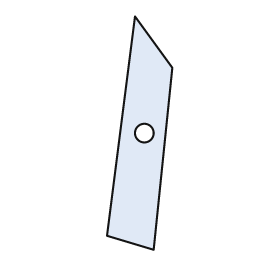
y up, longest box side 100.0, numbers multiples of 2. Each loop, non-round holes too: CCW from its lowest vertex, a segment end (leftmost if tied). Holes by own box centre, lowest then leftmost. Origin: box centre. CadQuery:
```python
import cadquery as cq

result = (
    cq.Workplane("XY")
    .moveTo(6.0, -50.0)
    .lineTo(14.0, 28.0)
    .lineTo(-2.0, 50.0)
    .lineTo(-14.0, -44.0)
    .close()
    .moveTo(2.0, 0.0)
    .circle(4.0)
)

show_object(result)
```